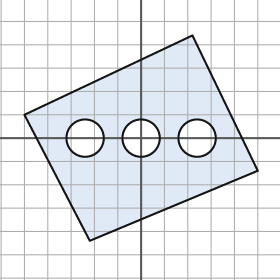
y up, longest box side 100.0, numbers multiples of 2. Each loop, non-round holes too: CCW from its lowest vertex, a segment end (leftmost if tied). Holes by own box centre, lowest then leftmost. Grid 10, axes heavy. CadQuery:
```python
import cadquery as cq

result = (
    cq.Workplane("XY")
    .moveTo(-22.0, -44.0)
    .lineTo(50.0, -14.0)
    .lineTo(22.0, 44.0)
    .lineTo(-50.0, 10.0)
    .close()
    .moveTo(-24.0, 0.0)
    .circle(8.0)
    .moveTo(0.0, 0.0)
    .circle(8.0)
    .moveTo(24.0, 0.0)
    .circle(8.0)
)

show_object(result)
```